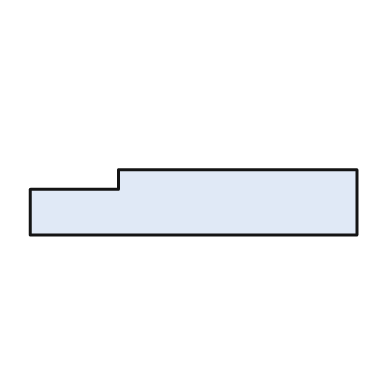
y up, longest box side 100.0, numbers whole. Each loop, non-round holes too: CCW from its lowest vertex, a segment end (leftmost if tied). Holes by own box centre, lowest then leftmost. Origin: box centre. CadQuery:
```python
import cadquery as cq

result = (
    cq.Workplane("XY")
    .moveTo(-50.0, -10.0)
    .lineTo(50.0, -10.0)
    .lineTo(50.0, 10.0)
    .lineTo(-23.0, 10.0)
    .lineTo(-23.0, 4.0)
    .lineTo(-50.0, 4.0)
    .close()
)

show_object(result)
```